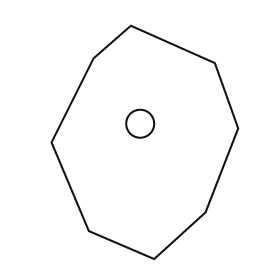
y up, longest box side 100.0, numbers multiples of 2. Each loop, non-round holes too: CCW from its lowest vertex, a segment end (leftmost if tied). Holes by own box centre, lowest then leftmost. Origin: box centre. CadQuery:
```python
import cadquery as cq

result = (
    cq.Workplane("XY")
    .moveTo(4.0, -50.0)
    .lineTo(26.0, -30.0)
    .lineTo(40.0, 6.0)
    .lineTo(30.0, 34.0)
    .lineTo(-6.0, 50.0)
    .lineTo(-22.0, 36.0)
    .lineTo(-40.0, 0.0)
    .lineTo(-24.0, -38.0)
    .close()
    .moveTo(-2.0, 8.0)
    .circle(6.0)
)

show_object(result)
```